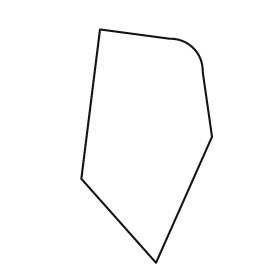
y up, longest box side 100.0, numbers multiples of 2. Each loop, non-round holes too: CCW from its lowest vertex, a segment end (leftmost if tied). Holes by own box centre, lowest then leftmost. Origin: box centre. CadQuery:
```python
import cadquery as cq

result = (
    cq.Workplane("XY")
    .moveTo(4.0, -50.0)
    .lineTo(28.0, 4.0)
    .lineTo(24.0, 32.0)
    .threePointArc((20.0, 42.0), (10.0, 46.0))
    .lineTo(-20.0, 50.0)
    .lineTo(-28.0, -14.0)
    .close()
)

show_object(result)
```